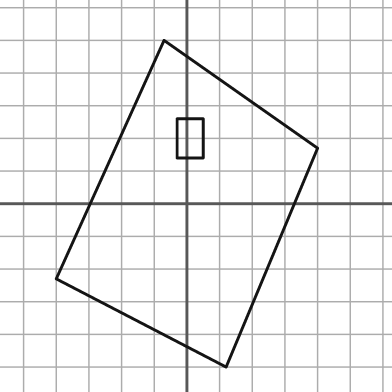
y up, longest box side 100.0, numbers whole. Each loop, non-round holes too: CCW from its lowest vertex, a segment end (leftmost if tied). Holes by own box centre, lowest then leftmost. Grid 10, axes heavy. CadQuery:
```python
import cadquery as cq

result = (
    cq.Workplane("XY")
    .moveTo(12.0, -50.0)
    .lineTo(40.0, 17.0)
    .lineTo(-7.0, 50.0)
    .lineTo(-40.0, -23.0)
    .close()
    .moveTo(-3.0, 14.0)
    .lineTo(5.0, 14.0)
    .lineTo(5.0, 26.0)
    .lineTo(-3.0, 26.0)
    .close()
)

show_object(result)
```